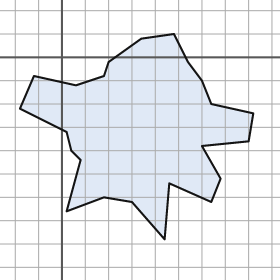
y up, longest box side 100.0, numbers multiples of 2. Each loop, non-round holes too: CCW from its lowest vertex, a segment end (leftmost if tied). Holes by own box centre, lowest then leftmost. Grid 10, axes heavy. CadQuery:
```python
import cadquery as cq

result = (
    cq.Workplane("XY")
    .moveTo(44.0, -78.0)
    .lineTo(46.0, -54.0)
    .lineTo(64.0, -62.0)
    .lineTo(68.0, -52.0)
    .lineTo(60.0, -38.0)
    .lineTo(80.0, -36.0)
    .lineTo(82.0, -24.0)
    .lineTo(64.0, -20.0)
    .lineTo(60.0, -10.0)
    .lineTo(54.0, -2.0)
    .lineTo(48.0, 10.0)
    .lineTo(34.0, 8.0)
    .lineTo(20.0, -2.0)
    .lineTo(18.0, -8.0)
    .lineTo(6.0, -12.0)
    .lineTo(-12.0, -8.0)
    .lineTo(-18.0, -22.0)
    .lineTo(2.0, -32.0)
    .lineTo(4.0, -40.0)
    .lineTo(8.0, -44.0)
    .lineTo(2.0, -66.0)
    .lineTo(18.0, -60.0)
    .lineTo(30.0, -62.0)
    .close()
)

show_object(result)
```